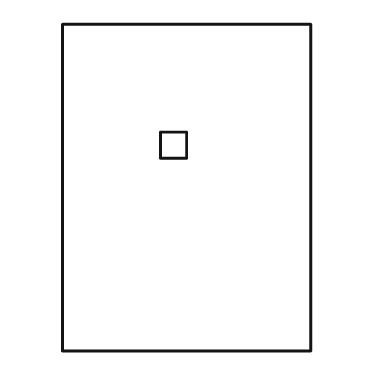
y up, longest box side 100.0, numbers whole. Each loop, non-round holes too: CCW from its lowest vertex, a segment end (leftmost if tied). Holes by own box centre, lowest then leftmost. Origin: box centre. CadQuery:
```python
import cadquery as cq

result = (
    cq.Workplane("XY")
    .moveTo(-38.0, -50.0)
    .lineTo(38.0, -50.0)
    .lineTo(38.0, 50.0)
    .lineTo(-38.0, 50.0)
    .close()
    .moveTo(-8.0, 9.0)
    .lineTo(0.0, 9.0)
    .lineTo(0.0, 17.0)
    .lineTo(-8.0, 17.0)
    .close()
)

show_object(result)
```